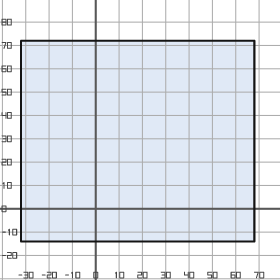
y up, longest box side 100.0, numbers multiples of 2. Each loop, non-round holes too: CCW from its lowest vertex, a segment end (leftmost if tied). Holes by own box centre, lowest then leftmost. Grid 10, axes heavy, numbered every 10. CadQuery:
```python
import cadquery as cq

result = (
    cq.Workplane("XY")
    .moveTo(-32.0, -14.0)
    .lineTo(68.0, -14.0)
    .lineTo(68.0, 72.0)
    .lineTo(-32.0, 72.0)
    .close()
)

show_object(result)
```